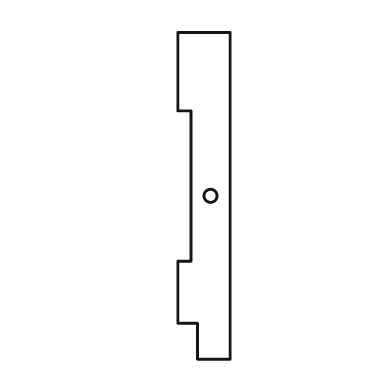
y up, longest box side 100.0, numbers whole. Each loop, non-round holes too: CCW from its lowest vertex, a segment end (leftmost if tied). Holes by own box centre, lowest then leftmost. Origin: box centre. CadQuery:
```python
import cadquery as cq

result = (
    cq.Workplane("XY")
    .moveTo(-2.0, -50.0)
    .lineTo(8.0, -50.0)
    .lineTo(8.0, 50.0)
    .lineTo(-8.0, 50.0)
    .lineTo(-8.0, 26.0)
    .lineTo(-4.0, 26.0)
    .lineTo(-4.0, -20.0)
    .lineTo(-8.0, -20.0)
    .lineTo(-8.0, -39.0)
    .lineTo(-2.0, -39.0)
    .close()
    .moveTo(2.0, 0.0)
    .circle(2.0)
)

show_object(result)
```